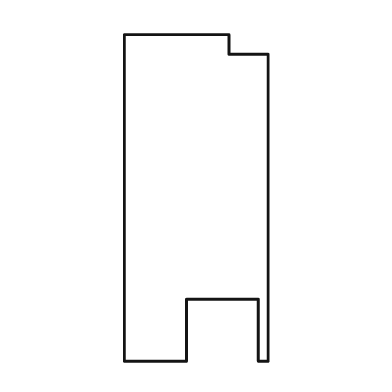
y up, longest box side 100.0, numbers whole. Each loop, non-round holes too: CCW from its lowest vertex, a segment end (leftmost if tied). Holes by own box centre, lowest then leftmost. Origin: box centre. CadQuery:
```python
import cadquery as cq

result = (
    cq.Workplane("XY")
    .moveTo(-22.0, -50.0)
    .lineTo(-3.0, -50.0)
    .lineTo(-3.0, -31.0)
    .lineTo(19.0, -31.0)
    .lineTo(19.0, -50.0)
    .lineTo(22.0, -50.0)
    .lineTo(22.0, 44.0)
    .lineTo(10.0, 44.0)
    .lineTo(10.0, 50.0)
    .lineTo(-22.0, 50.0)
    .close()
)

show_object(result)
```